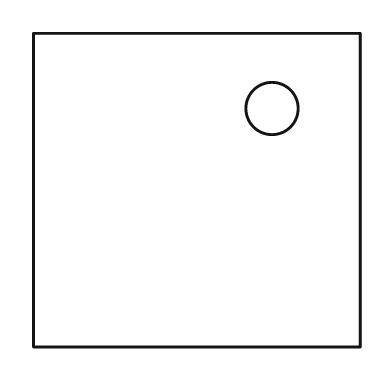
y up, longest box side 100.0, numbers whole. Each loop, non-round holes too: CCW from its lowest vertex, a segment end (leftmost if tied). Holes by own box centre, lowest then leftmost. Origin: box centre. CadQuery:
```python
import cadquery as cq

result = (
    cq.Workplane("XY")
    .moveTo(-50.0, -48.0)
    .lineTo(50.0, -48.0)
    .lineTo(50.0, 48.0)
    .lineTo(-50.0, 48.0)
    .close()
    .moveTo(23.0, 25.0)
    .circle(8.0)
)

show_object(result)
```